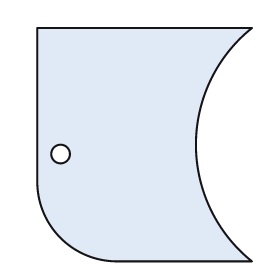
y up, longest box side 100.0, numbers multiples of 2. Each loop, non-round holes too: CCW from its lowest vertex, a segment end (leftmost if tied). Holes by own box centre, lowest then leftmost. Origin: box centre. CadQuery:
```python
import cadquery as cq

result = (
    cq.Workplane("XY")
    .moveTo(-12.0, -50.0)
    .lineTo(46.0, -50.0)
    .threePointArc((22.0, 0.0), (46.0, 50.0))
    .lineTo(-46.0, 50.0)
    .lineTo(-46.0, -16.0)
    .threePointArc((-36.0, -40.0), (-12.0, -50.0))
    .close()
    .moveTo(-36.0, -4.0)
    .circle(4.0)
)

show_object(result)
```